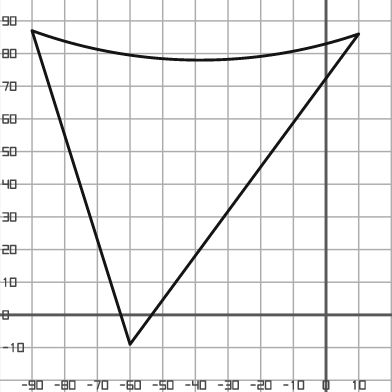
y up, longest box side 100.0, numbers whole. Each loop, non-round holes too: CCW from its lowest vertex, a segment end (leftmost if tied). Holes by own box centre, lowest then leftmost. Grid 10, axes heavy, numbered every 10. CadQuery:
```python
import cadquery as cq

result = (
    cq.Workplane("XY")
    .moveTo(-60.0, -9.0)
    .lineTo(10.0, 86.0)
    .threePointArc((-40.0, 78.0), (-90.0, 87.0))
    .close()
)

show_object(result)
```